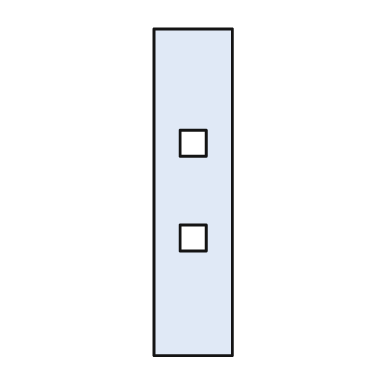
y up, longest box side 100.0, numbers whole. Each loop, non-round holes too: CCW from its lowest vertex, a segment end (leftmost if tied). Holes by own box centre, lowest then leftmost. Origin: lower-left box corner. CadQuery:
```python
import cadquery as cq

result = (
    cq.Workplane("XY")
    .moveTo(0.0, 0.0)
    .lineTo(24.0, 0.0)
    .lineTo(24.0, 100.0)
    .lineTo(0.0, 100.0)
    .close()
    .moveTo(8.0, 32.0)
    .lineTo(16.0, 32.0)
    .lineTo(16.0, 40.0)
    .lineTo(8.0, 40.0)
    .close()
    .moveTo(8.0, 61.0)
    .lineTo(16.0, 61.0)
    .lineTo(16.0, 69.0)
    .lineTo(8.0, 69.0)
    .close()
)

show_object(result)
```